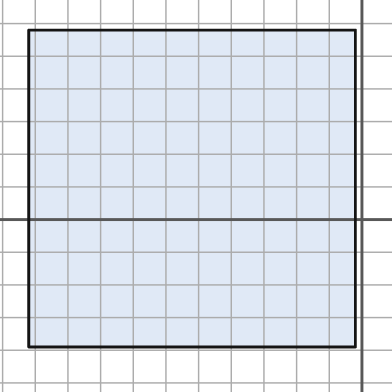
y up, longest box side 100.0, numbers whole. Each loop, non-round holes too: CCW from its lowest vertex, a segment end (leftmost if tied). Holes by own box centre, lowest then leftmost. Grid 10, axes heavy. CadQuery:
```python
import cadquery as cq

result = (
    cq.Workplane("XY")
    .moveTo(-102.0, -39.0)
    .lineTo(-2.0, -39.0)
    .lineTo(-2.0, 58.0)
    .lineTo(-102.0, 58.0)
    .close()
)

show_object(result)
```